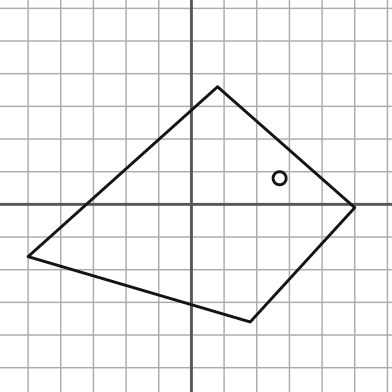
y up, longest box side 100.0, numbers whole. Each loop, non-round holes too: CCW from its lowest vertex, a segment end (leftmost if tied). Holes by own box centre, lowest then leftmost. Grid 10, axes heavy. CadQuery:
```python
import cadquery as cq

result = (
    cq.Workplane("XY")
    .moveTo(18.0, -36.0)
    .lineTo(50.0, -1.0)
    .lineTo(8.0, 36.0)
    .lineTo(-50.0, -16.0)
    .close()
    .moveTo(27.0, 8.0)
    .circle(2.0)
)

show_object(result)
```